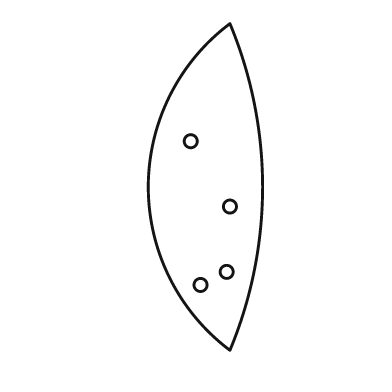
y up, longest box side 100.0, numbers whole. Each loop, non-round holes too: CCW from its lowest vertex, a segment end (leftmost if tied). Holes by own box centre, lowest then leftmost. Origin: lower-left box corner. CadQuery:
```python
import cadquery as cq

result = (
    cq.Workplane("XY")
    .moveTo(25.0, 0.0)
    .threePointArc((35.0, 50.0), (25.0, 100.0))
    .threePointArc((0.0, 50.0), (25.0, 0.0))
    .close()
    .moveTo(16.0, 20.0)
    .circle(2.0)
    .moveTo(24.0, 24.0)
    .circle(2.0)
    .moveTo(25.0, 44.0)
    .circle(2.0)
    .moveTo(13.0, 64.0)
    .circle(2.0)
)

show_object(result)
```